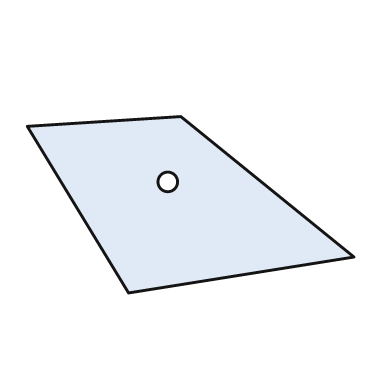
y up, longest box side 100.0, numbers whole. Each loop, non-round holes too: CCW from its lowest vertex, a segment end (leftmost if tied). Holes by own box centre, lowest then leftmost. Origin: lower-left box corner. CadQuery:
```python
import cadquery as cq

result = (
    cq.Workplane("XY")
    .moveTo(31.0, 0.0)
    .lineTo(100.0, 11.0)
    .lineTo(47.0, 54.0)
    .lineTo(0.0, 51.0)
    .close()
    .moveTo(43.0, 34.0)
    .circle(3.0)
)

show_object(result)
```